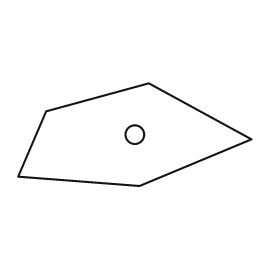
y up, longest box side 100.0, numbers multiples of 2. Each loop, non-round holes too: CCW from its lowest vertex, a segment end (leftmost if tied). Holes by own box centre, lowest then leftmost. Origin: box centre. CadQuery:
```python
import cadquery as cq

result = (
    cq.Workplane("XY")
    .moveTo(2.0, -22.0)
    .lineTo(50.0, -2.0)
    .lineTo(6.0, 22.0)
    .lineTo(-38.0, 10.0)
    .lineTo(-50.0, -18.0)
    .close()
    .moveTo(0.0, 0.0)
    .circle(4.0)
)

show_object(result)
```